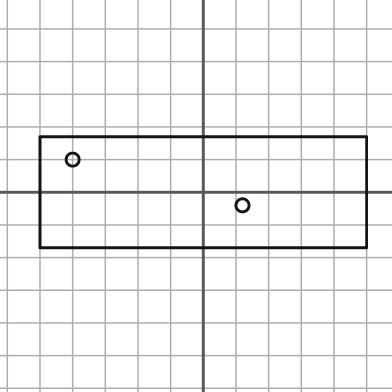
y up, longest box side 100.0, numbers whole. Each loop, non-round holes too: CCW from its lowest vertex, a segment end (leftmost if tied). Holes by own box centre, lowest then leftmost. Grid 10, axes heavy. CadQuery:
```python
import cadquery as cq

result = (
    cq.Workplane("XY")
    .moveTo(-50.0, -17.0)
    .lineTo(50.0, -17.0)
    .lineTo(50.0, 17.0)
    .lineTo(-50.0, 17.0)
    .close()
    .moveTo(12.0, -4.0)
    .circle(2.0)
    .moveTo(-40.0, 10.0)
    .circle(2.0)
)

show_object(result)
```